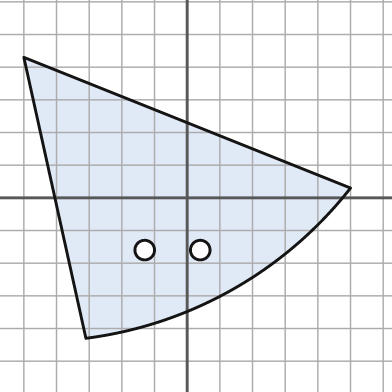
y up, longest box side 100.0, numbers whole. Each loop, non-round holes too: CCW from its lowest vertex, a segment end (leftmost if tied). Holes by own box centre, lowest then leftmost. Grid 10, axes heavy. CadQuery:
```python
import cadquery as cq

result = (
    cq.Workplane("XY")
    .moveTo(-31.0, -43.0)
    .threePointArc((14.0, -28.0), (50.0, 3.0))
    .lineTo(-50.0, 43.0)
    .close()
    .moveTo(-13.0, -16.0)
    .circle(3.0)
    .moveTo(4.0, -16.0)
    .circle(3.0)
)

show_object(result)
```